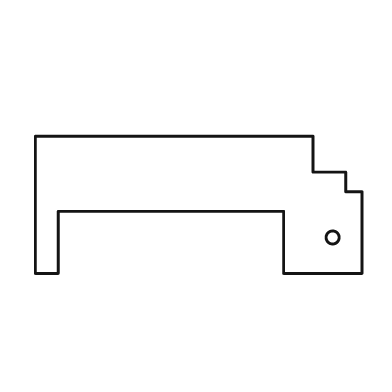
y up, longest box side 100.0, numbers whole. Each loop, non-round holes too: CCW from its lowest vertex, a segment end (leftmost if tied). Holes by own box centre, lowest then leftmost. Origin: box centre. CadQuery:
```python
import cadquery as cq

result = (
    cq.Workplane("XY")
    .moveTo(-50.0, -21.0)
    .lineTo(-43.0, -21.0)
    .lineTo(-43.0, -2.0)
    .lineTo(26.0, -2.0)
    .lineTo(26.0, -21.0)
    .lineTo(50.0, -21.0)
    .lineTo(50.0, 4.0)
    .lineTo(45.0, 4.0)
    .lineTo(45.0, 10.0)
    .lineTo(35.0, 10.0)
    .lineTo(35.0, 21.0)
    .lineTo(-50.0, 21.0)
    .close()
    .moveTo(41.0, -10.0)
    .circle(2.0)
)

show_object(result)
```